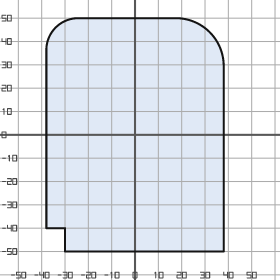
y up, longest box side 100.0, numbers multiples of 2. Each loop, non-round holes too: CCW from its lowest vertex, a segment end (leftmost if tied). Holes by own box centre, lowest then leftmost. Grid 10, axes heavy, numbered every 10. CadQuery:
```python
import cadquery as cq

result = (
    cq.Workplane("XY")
    .moveTo(-30.0, -50.0)
    .lineTo(38.0, -50.0)
    .lineTo(38.0, 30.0)
    .threePointArc((32.0, 44.0), (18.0, 50.0))
    .lineTo(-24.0, 50.0)
    .threePointArc((-34.0, 46.0), (-38.0, 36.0))
    .lineTo(-38.0, -40.0)
    .lineTo(-30.0, -40.0)
    .close()
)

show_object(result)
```